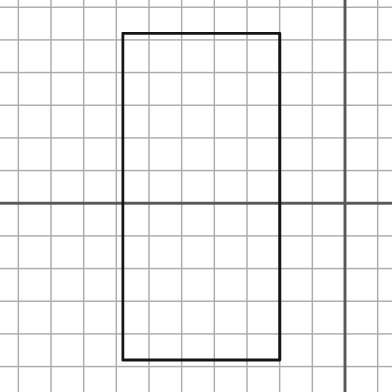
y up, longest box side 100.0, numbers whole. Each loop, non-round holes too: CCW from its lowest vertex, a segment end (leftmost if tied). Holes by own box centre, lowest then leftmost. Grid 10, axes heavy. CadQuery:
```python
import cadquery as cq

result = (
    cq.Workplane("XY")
    .moveTo(-68.0, -48.0)
    .lineTo(-20.0, -48.0)
    .lineTo(-20.0, 52.0)
    .lineTo(-68.0, 52.0)
    .close()
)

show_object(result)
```